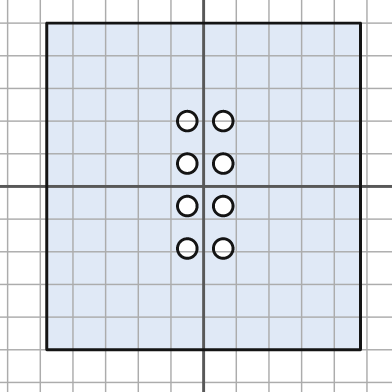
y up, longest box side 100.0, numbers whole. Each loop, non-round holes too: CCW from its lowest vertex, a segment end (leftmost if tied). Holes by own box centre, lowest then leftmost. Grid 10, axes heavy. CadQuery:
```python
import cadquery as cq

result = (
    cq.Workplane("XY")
    .moveTo(-48.0, -50.0)
    .lineTo(48.0, -50.0)
    .lineTo(48.0, 50.0)
    .lineTo(-48.0, 50.0)
    .close()
    .moveTo(-5.0, -19.0)
    .circle(3.0)
    .moveTo(6.0, -19.0)
    .circle(3.0)
    .moveTo(-5.0, -6.0)
    .circle(3.0)
    .moveTo(6.0, -6.0)
    .circle(3.0)
    .moveTo(-5.0, 7.0)
    .circle(3.0)
    .moveTo(6.0, 7.0)
    .circle(3.0)
    .moveTo(-5.0, 20.0)
    .circle(3.0)
    .moveTo(6.0, 20.0)
    .circle(3.0)
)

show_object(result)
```